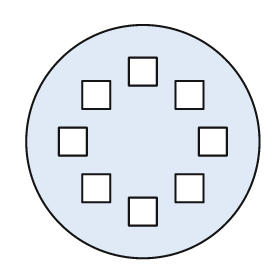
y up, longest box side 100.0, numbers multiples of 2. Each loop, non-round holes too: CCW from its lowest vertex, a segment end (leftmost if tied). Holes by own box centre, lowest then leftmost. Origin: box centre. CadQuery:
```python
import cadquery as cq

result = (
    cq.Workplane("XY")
    .moveTo(0.0, 0.0)
    .circle(50.0)
    .moveTo(-6.0, -36.0)
    .lineTo(6.0, -36.0)
    .lineTo(6.0, -24.0)
    .lineTo(-6.0, -24.0)
    .close()
    .moveTo(-26.0, -26.0)
    .lineTo(-14.0, -26.0)
    .lineTo(-14.0, -14.0)
    .lineTo(-26.0, -14.0)
    .close()
    .moveTo(14.0, -26.0)
    .lineTo(26.0, -26.0)
    .lineTo(26.0, -14.0)
    .lineTo(14.0, -14.0)
    .close()
    .moveTo(-36.0, -6.0)
    .lineTo(-24.0, -6.0)
    .lineTo(-24.0, 6.0)
    .lineTo(-36.0, 6.0)
    .close()
    .moveTo(24.0, -6.0)
    .lineTo(36.0, -6.0)
    .lineTo(36.0, 6.0)
    .lineTo(24.0, 6.0)
    .close()
    .moveTo(-26.0, 14.0)
    .lineTo(-14.0, 14.0)
    .lineTo(-14.0, 26.0)
    .lineTo(-26.0, 26.0)
    .close()
    .moveTo(14.0, 14.0)
    .lineTo(26.0, 14.0)
    .lineTo(26.0, 26.0)
    .lineTo(14.0, 26.0)
    .close()
    .moveTo(-6.0, 24.0)
    .lineTo(6.0, 24.0)
    .lineTo(6.0, 36.0)
    .lineTo(-6.0, 36.0)
    .close()
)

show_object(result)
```